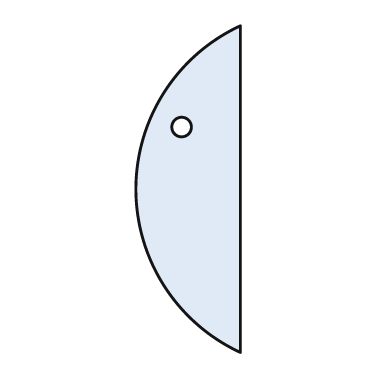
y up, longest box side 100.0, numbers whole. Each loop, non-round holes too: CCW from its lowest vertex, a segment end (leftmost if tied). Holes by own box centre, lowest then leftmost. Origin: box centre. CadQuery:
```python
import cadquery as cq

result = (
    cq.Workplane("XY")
    .moveTo(16.0, -50.0)
    .lineTo(16.0, 50.0)
    .threePointArc((-16.0, 0.0), (16.0, -50.0))
    .close()
    .moveTo(-2.0, 19.0)
    .circle(3.0)
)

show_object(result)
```